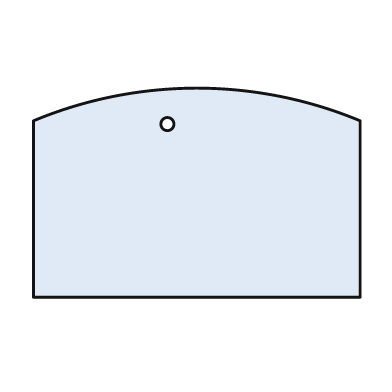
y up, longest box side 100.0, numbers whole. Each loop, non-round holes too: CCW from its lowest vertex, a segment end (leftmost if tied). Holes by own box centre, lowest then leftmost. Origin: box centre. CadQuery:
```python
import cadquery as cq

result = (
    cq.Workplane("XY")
    .moveTo(-50.0, -32.0)
    .lineTo(50.0, -32.0)
    .lineTo(50.0, 22.0)
    .threePointArc((0.0, 32.0), (-50.0, 22.0))
    .close()
    .moveTo(-9.0, 21.0)
    .circle(2.0)
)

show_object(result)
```